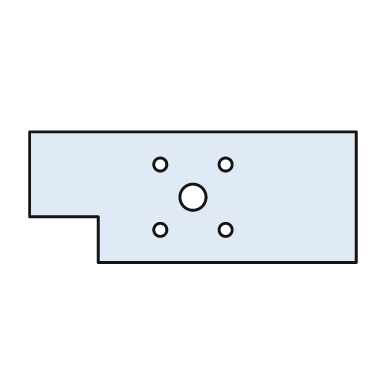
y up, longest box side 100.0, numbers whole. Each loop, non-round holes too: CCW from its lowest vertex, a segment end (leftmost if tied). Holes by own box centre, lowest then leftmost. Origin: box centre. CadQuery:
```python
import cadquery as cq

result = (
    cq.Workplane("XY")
    .moveTo(-29.0, -20.0)
    .lineTo(50.0, -20.0)
    .lineTo(50.0, 20.0)
    .lineTo(-50.0, 20.0)
    .lineTo(-50.0, -6.0)
    .lineTo(-29.0, -6.0)
    .close()
    .moveTo(-10.0, -10.0)
    .circle(2.0)
    .moveTo(10.0, -10.0)
    .circle(2.0)
    .moveTo(0.0, 0.0)
    .circle(4.0)
    .moveTo(-10.0, 10.0)
    .circle(2.0)
    .moveTo(10.0, 10.0)
    .circle(2.0)
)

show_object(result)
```